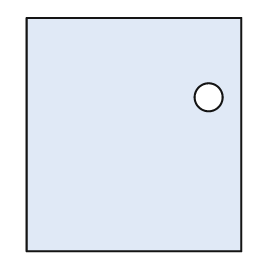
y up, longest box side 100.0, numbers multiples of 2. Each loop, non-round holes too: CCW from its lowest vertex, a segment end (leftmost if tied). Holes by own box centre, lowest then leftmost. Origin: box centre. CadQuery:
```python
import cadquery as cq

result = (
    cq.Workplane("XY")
    .moveTo(-46.0, -50.0)
    .lineTo(46.0, -50.0)
    .lineTo(46.0, 50.0)
    .lineTo(-46.0, 50.0)
    .close()
    .moveTo(32.0, 16.0)
    .circle(6.0)
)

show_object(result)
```